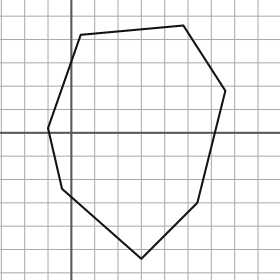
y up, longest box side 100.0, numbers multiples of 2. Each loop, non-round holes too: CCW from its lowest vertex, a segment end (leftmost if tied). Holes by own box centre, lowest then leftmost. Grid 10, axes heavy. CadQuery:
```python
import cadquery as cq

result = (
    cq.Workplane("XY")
    .moveTo(30.0, -54.0)
    .lineTo(54.0, -30.0)
    .lineTo(66.0, 18.0)
    .lineTo(48.0, 46.0)
    .lineTo(4.0, 42.0)
    .lineTo(-10.0, 2.0)
    .lineTo(-4.0, -24.0)
    .close()
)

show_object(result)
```